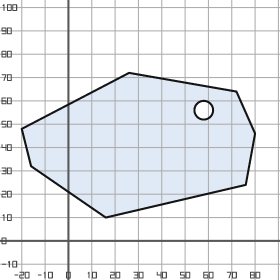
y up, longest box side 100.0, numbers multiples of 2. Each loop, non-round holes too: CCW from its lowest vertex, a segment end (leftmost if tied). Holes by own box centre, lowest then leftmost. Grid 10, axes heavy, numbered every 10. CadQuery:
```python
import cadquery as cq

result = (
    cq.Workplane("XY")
    .moveTo(16.0, 10.0)
    .lineTo(76.0, 24.0)
    .lineTo(80.0, 46.0)
    .lineTo(72.0, 64.0)
    .lineTo(26.0, 72.0)
    .lineTo(-20.0, 48.0)
    .lineTo(-16.0, 32.0)
    .close()
    .moveTo(58.0, 56.0)
    .circle(4.0)
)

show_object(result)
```